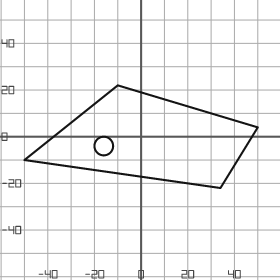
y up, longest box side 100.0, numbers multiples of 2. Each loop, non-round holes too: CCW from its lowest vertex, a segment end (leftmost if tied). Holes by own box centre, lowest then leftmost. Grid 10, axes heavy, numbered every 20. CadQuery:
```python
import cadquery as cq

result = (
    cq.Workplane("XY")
    .moveTo(34.0, -22.0)
    .lineTo(50.0, 4.0)
    .lineTo(-10.0, 22.0)
    .lineTo(-50.0, -10.0)
    .close()
    .moveTo(-16.0, -4.0)
    .circle(4.0)
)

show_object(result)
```